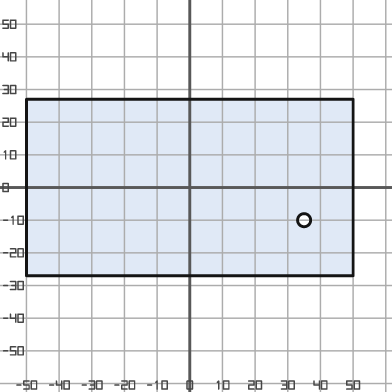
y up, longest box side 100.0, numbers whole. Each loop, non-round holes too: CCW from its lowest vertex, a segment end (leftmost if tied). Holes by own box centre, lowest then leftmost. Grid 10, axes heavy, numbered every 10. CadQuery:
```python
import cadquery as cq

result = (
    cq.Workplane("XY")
    .moveTo(-50.0, -27.0)
    .lineTo(50.0, -27.0)
    .lineTo(50.0, 27.0)
    .lineTo(-50.0, 27.0)
    .close()
    .moveTo(35.0, -10.0)
    .circle(2.0)
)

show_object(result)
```